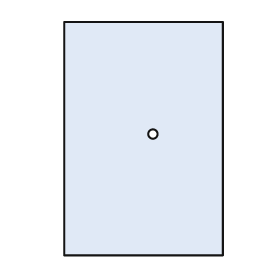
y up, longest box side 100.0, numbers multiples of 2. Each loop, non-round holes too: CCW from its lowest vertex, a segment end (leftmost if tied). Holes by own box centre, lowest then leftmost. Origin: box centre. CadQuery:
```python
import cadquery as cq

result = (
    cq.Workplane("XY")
    .moveTo(-34.0, -50.0)
    .lineTo(34.0, -50.0)
    .lineTo(34.0, 50.0)
    .lineTo(-34.0, 50.0)
    .close()
    .moveTo(4.0, 2.0)
    .circle(2.0)
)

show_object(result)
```